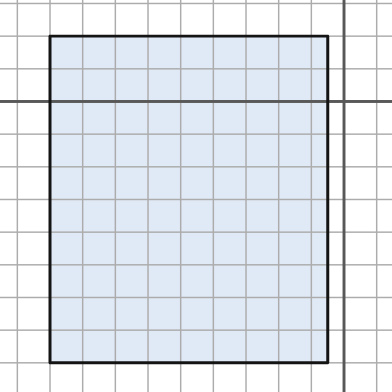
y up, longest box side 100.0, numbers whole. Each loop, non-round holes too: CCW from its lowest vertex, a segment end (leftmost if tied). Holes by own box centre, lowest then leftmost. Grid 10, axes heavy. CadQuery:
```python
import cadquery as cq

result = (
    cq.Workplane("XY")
    .moveTo(-90.0, -80.0)
    .lineTo(-5.0, -80.0)
    .lineTo(-5.0, 20.0)
    .lineTo(-90.0, 20.0)
    .close()
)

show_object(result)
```